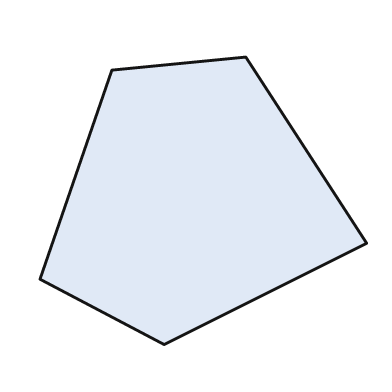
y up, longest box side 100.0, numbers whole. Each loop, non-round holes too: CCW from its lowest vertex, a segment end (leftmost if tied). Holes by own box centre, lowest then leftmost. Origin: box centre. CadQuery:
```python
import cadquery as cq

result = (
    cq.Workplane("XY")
    .moveTo(-12.0, -44.0)
    .lineTo(50.0, -13.0)
    .lineTo(13.0, 44.0)
    .lineTo(-28.0, 40.0)
    .lineTo(-50.0, -24.0)
    .close()
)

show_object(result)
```